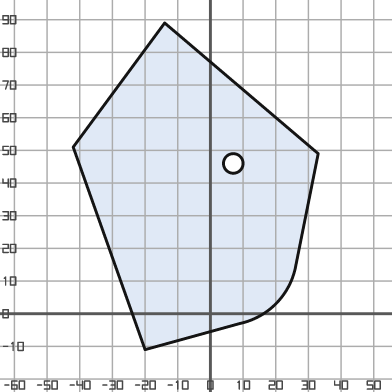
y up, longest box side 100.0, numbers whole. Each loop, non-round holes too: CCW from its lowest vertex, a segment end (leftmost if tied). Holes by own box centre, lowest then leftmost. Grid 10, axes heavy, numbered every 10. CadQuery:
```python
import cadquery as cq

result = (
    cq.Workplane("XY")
    .moveTo(-20.0, -11.0)
    .lineTo(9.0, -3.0)
    .threePointArc((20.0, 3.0), (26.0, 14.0))
    .lineTo(33.0, 49.0)
    .lineTo(-14.0, 89.0)
    .lineTo(-42.0, 51.0)
    .close()
    .moveTo(7.0, 46.0)
    .circle(3.0)
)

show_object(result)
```